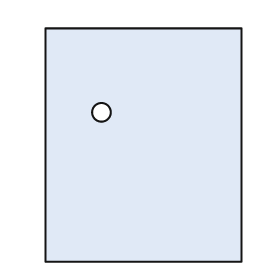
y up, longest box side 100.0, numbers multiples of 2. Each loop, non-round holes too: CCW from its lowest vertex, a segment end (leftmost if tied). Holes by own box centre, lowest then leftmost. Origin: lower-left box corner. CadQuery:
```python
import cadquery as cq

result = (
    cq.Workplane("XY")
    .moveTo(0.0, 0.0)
    .lineTo(84.0, 0.0)
    .lineTo(84.0, 100.0)
    .lineTo(0.0, 100.0)
    .close()
    .moveTo(24.0, 64.0)
    .circle(4.0)
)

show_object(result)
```